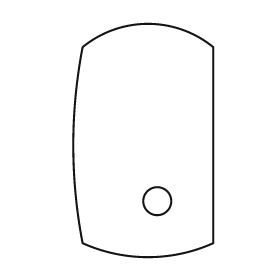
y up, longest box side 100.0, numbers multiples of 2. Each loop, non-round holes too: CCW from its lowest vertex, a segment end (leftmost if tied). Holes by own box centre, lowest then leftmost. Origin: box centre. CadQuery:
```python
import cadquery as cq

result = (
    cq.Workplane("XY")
    .moveTo(-26.0, -44.0)
    .threePointArc((2.0, -50.0), (30.0, -44.0))
    .lineTo(30.0, 40.0)
    .threePointArc((2.0, 50.0), (-26.0, 40.0))
    .threePointArc((-30.0, -2.0), (-26.0, -44.0))
    .close()
    .moveTo(6.0, -26.0)
    .circle(6.0)
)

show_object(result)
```